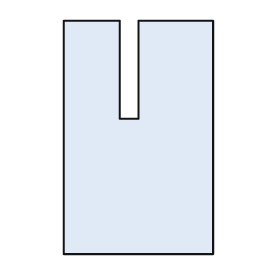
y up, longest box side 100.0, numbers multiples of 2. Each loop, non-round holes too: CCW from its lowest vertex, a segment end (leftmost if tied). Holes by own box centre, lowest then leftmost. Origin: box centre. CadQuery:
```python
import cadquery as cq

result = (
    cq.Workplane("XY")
    .moveTo(-32.0, -50.0)
    .lineTo(32.0, -50.0)
    .lineTo(32.0, 50.0)
    .lineTo(0.0, 50.0)
    .lineTo(0.0, 8.0)
    .lineTo(-8.0, 8.0)
    .lineTo(-8.0, 50.0)
    .lineTo(-32.0, 50.0)
    .close()
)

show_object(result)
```